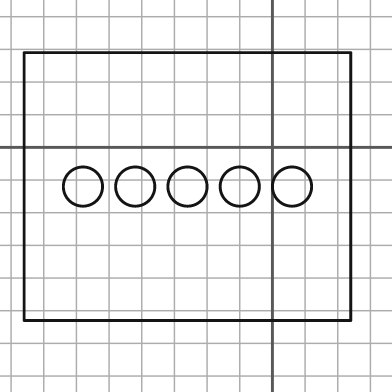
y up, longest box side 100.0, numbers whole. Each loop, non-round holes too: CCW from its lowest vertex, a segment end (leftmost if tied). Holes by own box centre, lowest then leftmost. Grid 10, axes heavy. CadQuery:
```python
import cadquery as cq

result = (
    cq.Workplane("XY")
    .moveTo(-76.0, -53.0)
    .lineTo(24.0, -53.0)
    .lineTo(24.0, 29.0)
    .lineTo(-76.0, 29.0)
    .close()
    .moveTo(-58.0, -12.0)
    .circle(6.0)
    .moveTo(-42.0, -12.0)
    .circle(6.0)
    .moveTo(-26.0, -12.0)
    .circle(6.0)
    .moveTo(-10.0, -12.0)
    .circle(6.0)
    .moveTo(6.0, -12.0)
    .circle(6.0)
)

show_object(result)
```